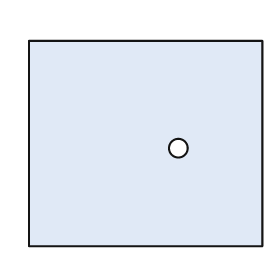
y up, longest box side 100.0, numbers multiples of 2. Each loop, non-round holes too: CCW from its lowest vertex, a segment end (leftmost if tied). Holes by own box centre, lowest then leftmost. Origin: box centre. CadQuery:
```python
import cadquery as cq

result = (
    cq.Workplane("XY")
    .moveTo(-50.0, -44.0)
    .lineTo(50.0, -44.0)
    .lineTo(50.0, 44.0)
    .lineTo(-50.0, 44.0)
    .close()
    .moveTo(14.0, -2.0)
    .circle(4.0)
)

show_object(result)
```